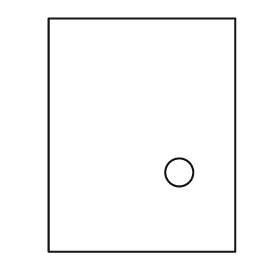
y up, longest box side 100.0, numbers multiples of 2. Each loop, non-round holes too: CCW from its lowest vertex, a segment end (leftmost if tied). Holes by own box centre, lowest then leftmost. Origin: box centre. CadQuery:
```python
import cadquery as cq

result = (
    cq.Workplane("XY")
    .moveTo(-40.0, -50.0)
    .lineTo(40.0, -50.0)
    .lineTo(40.0, 50.0)
    .lineTo(-40.0, 50.0)
    .close()
    .moveTo(16.0, -16.0)
    .circle(6.0)
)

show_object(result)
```